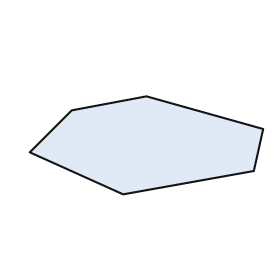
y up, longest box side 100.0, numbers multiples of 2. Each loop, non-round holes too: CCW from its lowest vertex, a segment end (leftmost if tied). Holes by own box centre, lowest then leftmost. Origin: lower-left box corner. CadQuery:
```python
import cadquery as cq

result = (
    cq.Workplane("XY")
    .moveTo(40.0, 0.0)
    .lineTo(96.0, 10.0)
    .lineTo(100.0, 28.0)
    .lineTo(50.0, 42.0)
    .lineTo(18.0, 36.0)
    .lineTo(0.0, 18.0)
    .close()
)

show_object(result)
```